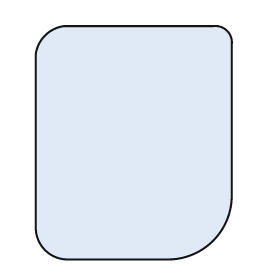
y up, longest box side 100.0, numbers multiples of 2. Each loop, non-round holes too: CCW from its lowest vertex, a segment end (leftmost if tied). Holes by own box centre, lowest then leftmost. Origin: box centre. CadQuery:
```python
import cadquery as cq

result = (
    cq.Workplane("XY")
    .moveTo(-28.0, -50.0)
    .lineTo(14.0, -50.0)
    .threePointArc((34.0, -42.0), (42.0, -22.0))
    .lineTo(42.0, 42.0)
    .threePointArc((40.0, 48.0), (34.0, 50.0))
    .lineTo(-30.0, 50.0)
    .threePointArc((-38.0, 46.0), (-42.0, 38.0))
    .lineTo(-42.0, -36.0)
    .threePointArc((-38.0, -46.0), (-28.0, -50.0))
    .close()
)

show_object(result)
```